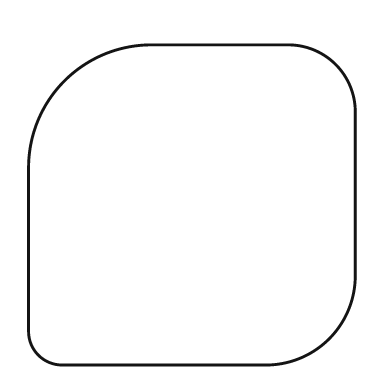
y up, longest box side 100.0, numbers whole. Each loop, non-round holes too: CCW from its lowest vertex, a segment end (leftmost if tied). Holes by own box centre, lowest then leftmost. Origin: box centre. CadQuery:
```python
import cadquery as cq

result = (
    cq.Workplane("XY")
    .moveTo(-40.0, -49.0)
    .lineTo(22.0, -49.0)
    .threePointArc((42.0, -41.0), (50.0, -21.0))
    .lineTo(50.0, 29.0)
    .threePointArc((44.0, 43.0), (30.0, 49.0))
    .lineTo(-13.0, 49.0)
    .threePointArc((-39.0, 38.0), (-50.0, 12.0))
    .lineTo(-50.0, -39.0)
    .threePointArc((-47.0, -46.0), (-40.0, -49.0))
    .close()
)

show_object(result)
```